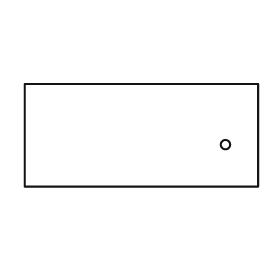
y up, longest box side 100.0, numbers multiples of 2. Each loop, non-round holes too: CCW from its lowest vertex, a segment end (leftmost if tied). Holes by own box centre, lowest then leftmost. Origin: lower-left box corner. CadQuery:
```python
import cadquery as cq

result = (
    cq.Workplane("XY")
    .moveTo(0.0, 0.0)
    .lineTo(100.0, 0.0)
    .lineTo(100.0, 44.0)
    .lineTo(0.0, 44.0)
    .close()
    .moveTo(86.0, 18.0)
    .circle(2.0)
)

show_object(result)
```